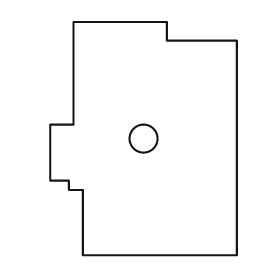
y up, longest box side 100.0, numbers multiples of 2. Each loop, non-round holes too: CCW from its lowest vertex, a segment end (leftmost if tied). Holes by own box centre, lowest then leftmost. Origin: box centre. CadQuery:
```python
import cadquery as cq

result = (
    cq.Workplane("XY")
    .moveTo(-26.0, -50.0)
    .lineTo(40.0, -50.0)
    .lineTo(40.0, 42.0)
    .lineTo(10.0, 42.0)
    .lineTo(10.0, 50.0)
    .lineTo(-30.0, 50.0)
    .lineTo(-30.0, 6.0)
    .lineTo(-40.0, 6.0)
    .lineTo(-40.0, -18.0)
    .lineTo(-32.0, -18.0)
    .lineTo(-32.0, -22.0)
    .lineTo(-26.0, -22.0)
    .close()
    .moveTo(0.0, 0.0)
    .circle(6.0)
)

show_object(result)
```